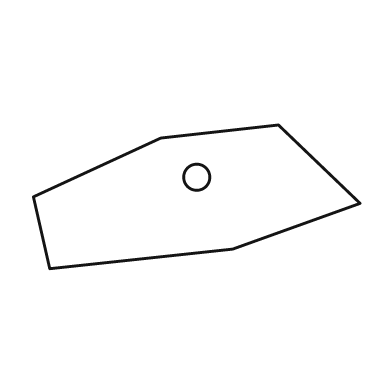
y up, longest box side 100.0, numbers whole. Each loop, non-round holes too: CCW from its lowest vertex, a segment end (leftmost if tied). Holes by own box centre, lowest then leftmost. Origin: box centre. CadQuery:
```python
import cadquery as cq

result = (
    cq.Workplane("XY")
    .moveTo(-45.0, -22.0)
    .lineTo(11.0, -16.0)
    .lineTo(50.0, -2.0)
    .lineTo(25.0, 22.0)
    .lineTo(-11.0, 18.0)
    .lineTo(-50.0, 0.0)
    .close()
    .moveTo(0.0, 6.0)
    .circle(4.0)
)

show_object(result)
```